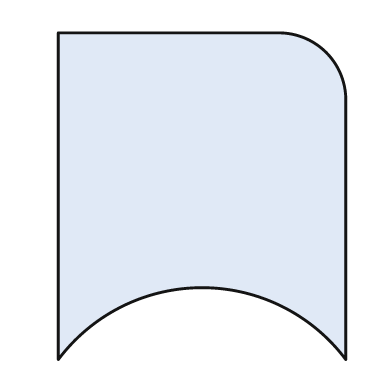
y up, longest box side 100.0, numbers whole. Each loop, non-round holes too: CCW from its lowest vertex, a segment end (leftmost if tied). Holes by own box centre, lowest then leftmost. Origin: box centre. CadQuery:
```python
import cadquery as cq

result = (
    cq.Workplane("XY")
    .moveTo(-44.0, -50.0)
    .threePointArc((0.0, -28.0), (44.0, -50.0))
    .lineTo(44.0, 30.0)
    .threePointArc((38.0, 44.0), (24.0, 50.0))
    .lineTo(-44.0, 50.0)
    .close()
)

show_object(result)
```